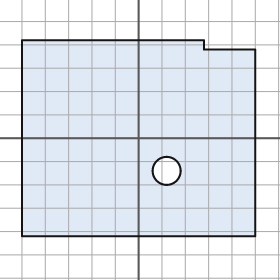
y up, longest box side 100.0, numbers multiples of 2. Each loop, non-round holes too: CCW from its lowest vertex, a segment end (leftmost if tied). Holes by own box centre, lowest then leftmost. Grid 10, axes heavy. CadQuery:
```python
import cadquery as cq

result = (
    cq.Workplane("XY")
    .moveTo(-50.0, -42.0)
    .lineTo(50.0, -42.0)
    .lineTo(50.0, 38.0)
    .lineTo(28.0, 38.0)
    .lineTo(28.0, 42.0)
    .lineTo(-50.0, 42.0)
    .close()
    .moveTo(12.0, -14.0)
    .circle(6.0)
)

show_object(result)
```